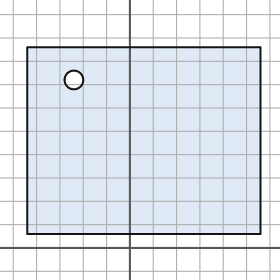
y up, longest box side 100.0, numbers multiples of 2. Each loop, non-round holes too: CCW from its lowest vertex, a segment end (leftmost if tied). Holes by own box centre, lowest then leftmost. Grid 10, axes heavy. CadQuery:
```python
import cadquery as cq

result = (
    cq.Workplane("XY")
    .moveTo(-44.0, 6.0)
    .lineTo(56.0, 6.0)
    .lineTo(56.0, 86.0)
    .lineTo(-44.0, 86.0)
    .close()
    .moveTo(-24.0, 72.0)
    .circle(4.0)
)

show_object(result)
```